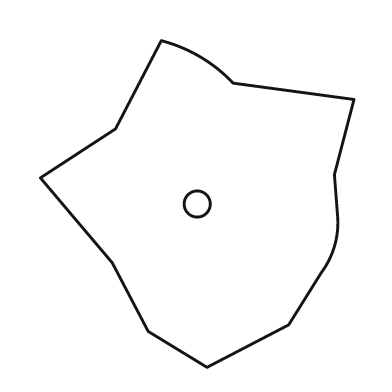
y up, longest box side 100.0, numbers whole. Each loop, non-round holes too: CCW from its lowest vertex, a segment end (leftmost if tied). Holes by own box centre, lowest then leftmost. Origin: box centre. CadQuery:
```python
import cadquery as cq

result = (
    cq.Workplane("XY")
    .moveTo(3.0, -50.0)
    .lineTo(28.0, -37.0)
    .lineTo(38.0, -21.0)
    .threePointArc((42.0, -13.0), (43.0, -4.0))
    .lineTo(42.0, 9.0)
    .lineTo(48.0, 32.0)
    .lineTo(11.0, 37.0)
    .threePointArc((1.0, 45.0), (-11.0, 50.0))
    .lineTo(-25.0, 23.0)
    .lineTo(-48.0, 8.0)
    .lineTo(-26.0, -18.0)
    .lineTo(-15.0, -39.0)
    .close()
    .moveTo(0.0, 0.0)
    .circle(4.0)
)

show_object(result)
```